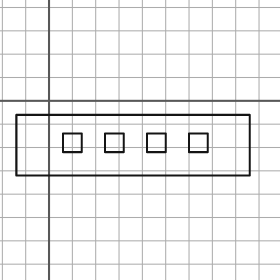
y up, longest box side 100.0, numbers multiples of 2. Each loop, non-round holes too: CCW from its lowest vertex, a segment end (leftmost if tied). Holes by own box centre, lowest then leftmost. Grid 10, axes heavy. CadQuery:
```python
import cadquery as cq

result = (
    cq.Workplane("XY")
    .moveTo(-14.0, -32.0)
    .lineTo(86.0, -32.0)
    .lineTo(86.0, -6.0)
    .lineTo(-14.0, -6.0)
    .close()
    .moveTo(6.0, -22.0)
    .lineTo(14.0, -22.0)
    .lineTo(14.0, -14.0)
    .lineTo(6.0, -14.0)
    .close()
    .moveTo(24.0, -22.0)
    .lineTo(32.0, -22.0)
    .lineTo(32.0, -14.0)
    .lineTo(24.0, -14.0)
    .close()
    .moveTo(42.0, -22.0)
    .lineTo(50.0, -22.0)
    .lineTo(50.0, -14.0)
    .lineTo(42.0, -14.0)
    .close()
    .moveTo(60.0, -22.0)
    .lineTo(68.0, -22.0)
    .lineTo(68.0, -14.0)
    .lineTo(60.0, -14.0)
    .close()
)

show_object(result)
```